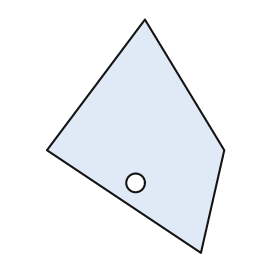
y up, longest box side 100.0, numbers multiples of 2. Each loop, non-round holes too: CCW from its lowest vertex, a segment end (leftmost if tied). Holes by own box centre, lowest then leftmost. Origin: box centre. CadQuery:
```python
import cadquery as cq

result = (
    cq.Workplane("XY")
    .moveTo(28.0, -50.0)
    .lineTo(38.0, -6.0)
    .lineTo(4.0, 50.0)
    .lineTo(-38.0, -6.0)
    .close()
    .moveTo(0.0, -20.0)
    .circle(4.0)
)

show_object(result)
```